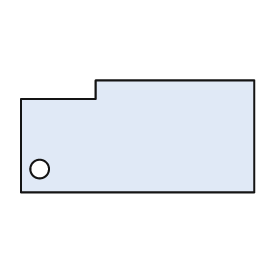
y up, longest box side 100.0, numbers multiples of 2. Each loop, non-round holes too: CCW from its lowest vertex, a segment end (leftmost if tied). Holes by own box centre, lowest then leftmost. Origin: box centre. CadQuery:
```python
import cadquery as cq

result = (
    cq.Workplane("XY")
    .moveTo(-50.0, -24.0)
    .lineTo(50.0, -24.0)
    .lineTo(50.0, 24.0)
    .lineTo(-18.0, 24.0)
    .lineTo(-18.0, 16.0)
    .lineTo(-50.0, 16.0)
    .close()
    .moveTo(-42.0, -14.0)
    .circle(4.0)
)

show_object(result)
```